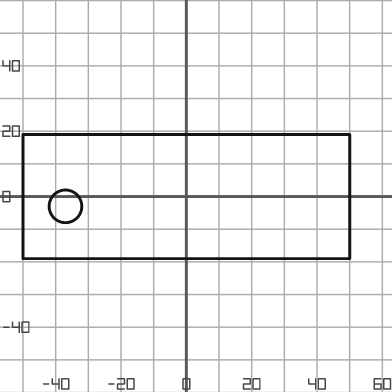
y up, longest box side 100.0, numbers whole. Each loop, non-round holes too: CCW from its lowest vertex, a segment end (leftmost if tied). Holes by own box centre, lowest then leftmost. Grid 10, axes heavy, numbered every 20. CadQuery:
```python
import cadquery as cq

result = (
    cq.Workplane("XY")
    .moveTo(-50.0, -19.0)
    .lineTo(50.0, -19.0)
    .lineTo(50.0, 19.0)
    .lineTo(-50.0, 19.0)
    .close()
    .moveTo(-37.0, -3.0)
    .circle(5.0)
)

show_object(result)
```